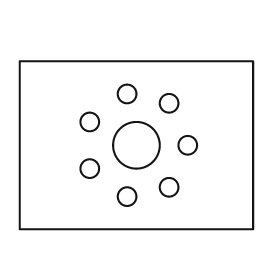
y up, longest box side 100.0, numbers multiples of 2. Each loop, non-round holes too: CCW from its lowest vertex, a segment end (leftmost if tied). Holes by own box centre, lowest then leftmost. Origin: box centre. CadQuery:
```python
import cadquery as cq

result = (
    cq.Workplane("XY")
    .moveTo(-50.0, -36.0)
    .lineTo(50.0, -36.0)
    .lineTo(50.0, 36.0)
    .lineTo(-50.0, 36.0)
    .close()
    .moveTo(-4.0, -22.0)
    .circle(4.0)
    .moveTo(14.0, -18.0)
    .circle(4.0)
    .moveTo(-20.0, -10.0)
    .circle(4.0)
    .moveTo(0.0, 0.0)
    .circle(10.0)
    .moveTo(22.0, 0.0)
    .circle(4.0)
    .moveTo(-20.0, 10.0)
    .circle(4.0)
    .moveTo(14.0, 18.0)
    .circle(4.0)
    .moveTo(-4.0, 22.0)
    .circle(4.0)
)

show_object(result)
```